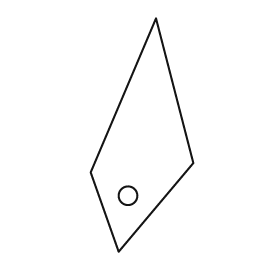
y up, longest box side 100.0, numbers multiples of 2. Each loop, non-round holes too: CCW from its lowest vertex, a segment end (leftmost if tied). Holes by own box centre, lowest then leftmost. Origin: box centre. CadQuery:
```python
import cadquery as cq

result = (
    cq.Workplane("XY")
    .moveTo(-10.0, -50.0)
    .lineTo(22.0, -12.0)
    .lineTo(6.0, 50.0)
    .lineTo(-22.0, -16.0)
    .close()
    .moveTo(-6.0, -26.0)
    .circle(4.0)
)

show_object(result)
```